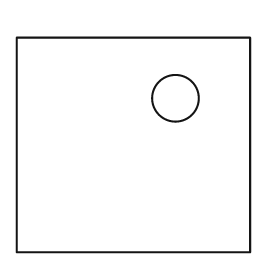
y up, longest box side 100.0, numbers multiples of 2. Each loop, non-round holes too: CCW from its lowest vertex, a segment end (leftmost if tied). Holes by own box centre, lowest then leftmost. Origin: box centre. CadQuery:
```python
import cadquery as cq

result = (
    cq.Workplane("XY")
    .moveTo(-50.0, -46.0)
    .lineTo(50.0, -46.0)
    .lineTo(50.0, 46.0)
    .lineTo(-50.0, 46.0)
    .close()
    .moveTo(18.0, 20.0)
    .circle(10.0)
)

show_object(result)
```